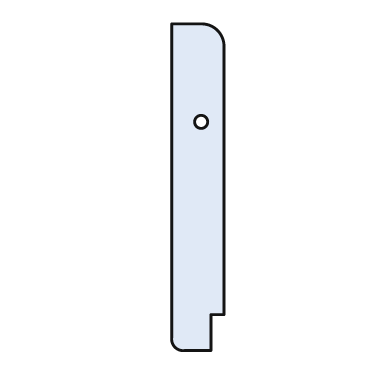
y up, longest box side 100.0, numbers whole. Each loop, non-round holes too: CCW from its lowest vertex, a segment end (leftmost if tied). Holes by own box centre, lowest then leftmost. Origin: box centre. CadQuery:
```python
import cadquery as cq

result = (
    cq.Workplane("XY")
    .moveTo(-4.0, -50.0)
    .lineTo(4.0, -50.0)
    .lineTo(4.0, -39.0)
    .lineTo(8.0, -39.0)
    .lineTo(8.0, 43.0)
    .threePointArc((6.0, 48.0), (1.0, 50.0))
    .lineTo(-8.0, 50.0)
    .lineTo(-8.0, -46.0)
    .threePointArc((-7.0, -49.0), (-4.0, -50.0))
    .close()
    .moveTo(1.0, 20.0)
    .circle(2.0)
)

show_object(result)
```